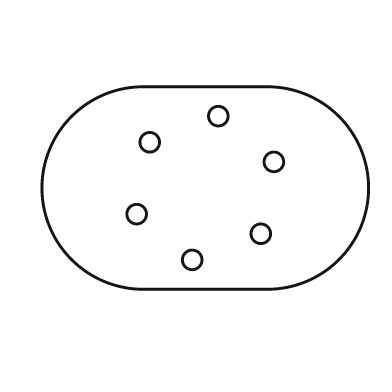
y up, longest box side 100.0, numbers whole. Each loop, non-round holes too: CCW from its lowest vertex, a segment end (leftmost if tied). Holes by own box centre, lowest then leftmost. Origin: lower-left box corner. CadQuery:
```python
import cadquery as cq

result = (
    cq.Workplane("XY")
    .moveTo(31.0, 0.0)
    .lineTo(69.0, 0.0)
    .threePointArc((100.0, 31.0), (69.0, 62.0))
    .lineTo(31.0, 62.0)
    .threePointArc((0.0, 31.0), (31.0, 0.0))
    .close()
    .moveTo(46.0, 9.0)
    .circle(3.0)
    .moveTo(67.0, 17.0)
    .circle(3.0)
    .moveTo(29.0, 23.0)
    .circle(3.0)
    .moveTo(71.0, 39.0)
    .circle(3.0)
    .moveTo(33.0, 45.0)
    .circle(3.0)
    .moveTo(54.0, 53.0)
    .circle(3.0)
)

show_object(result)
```